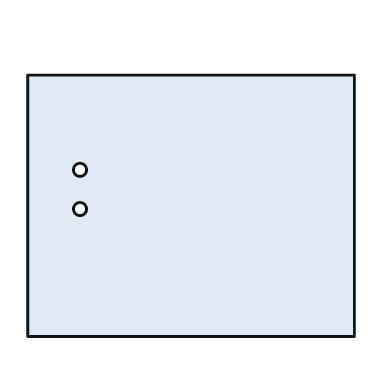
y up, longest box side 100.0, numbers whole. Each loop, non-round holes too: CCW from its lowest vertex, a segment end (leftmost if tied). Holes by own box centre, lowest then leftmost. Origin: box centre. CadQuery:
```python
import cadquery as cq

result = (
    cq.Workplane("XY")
    .moveTo(-50.0, -40.0)
    .lineTo(50.0, -40.0)
    .lineTo(50.0, 40.0)
    .lineTo(-50.0, 40.0)
    .close()
    .moveTo(-34.0, -1.0)
    .circle(2.0)
    .moveTo(-34.0, 11.0)
    .circle(2.0)
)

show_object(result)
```